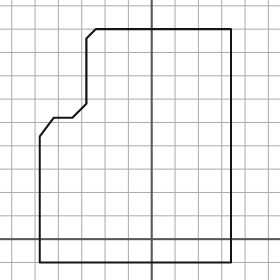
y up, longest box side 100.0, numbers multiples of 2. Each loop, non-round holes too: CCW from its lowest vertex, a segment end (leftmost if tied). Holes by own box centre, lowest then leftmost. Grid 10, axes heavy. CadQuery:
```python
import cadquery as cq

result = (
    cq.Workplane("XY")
    .moveTo(-48.0, -10.0)
    .lineTo(34.0, -10.0)
    .lineTo(34.0, 90.0)
    .lineTo(-24.0, 90.0)
    .lineTo(-28.0, 86.0)
    .lineTo(-28.0, 58.0)
    .lineTo(-34.0, 52.0)
    .lineTo(-42.0, 52.0)
    .lineTo(-48.0, 44.0)
    .close()
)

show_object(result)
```